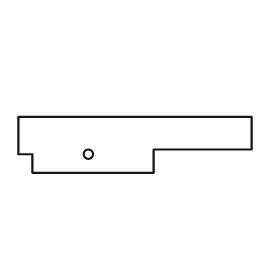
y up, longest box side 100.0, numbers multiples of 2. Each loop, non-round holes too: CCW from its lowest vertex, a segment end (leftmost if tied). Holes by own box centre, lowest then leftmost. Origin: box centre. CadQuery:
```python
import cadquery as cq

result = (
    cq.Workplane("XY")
    .moveTo(-44.0, -12.0)
    .lineTo(8.0, -12.0)
    .lineTo(8.0, -2.0)
    .lineTo(50.0, -2.0)
    .lineTo(50.0, 12.0)
    .lineTo(-50.0, 12.0)
    .lineTo(-50.0, -4.0)
    .lineTo(-44.0, -4.0)
    .close()
    .moveTo(-20.0, -4.0)
    .circle(2.0)
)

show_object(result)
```